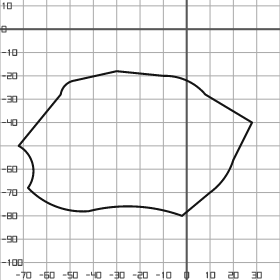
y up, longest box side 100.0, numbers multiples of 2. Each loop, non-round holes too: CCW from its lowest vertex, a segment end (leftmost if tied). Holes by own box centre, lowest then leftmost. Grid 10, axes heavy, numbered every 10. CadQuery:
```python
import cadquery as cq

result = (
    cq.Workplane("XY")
    .moveTo(-2.0, -80.0)
    .lineTo(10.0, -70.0)
    .threePointArc((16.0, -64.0), (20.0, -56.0))
    .lineTo(28.0, -40.0)
    .lineTo(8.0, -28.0)
    .threePointArc((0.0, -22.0), (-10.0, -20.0))
    .lineTo(-30.0, -18.0)
    .lineTo(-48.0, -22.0)
    .threePointArc((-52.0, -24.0), (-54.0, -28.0))
    .lineTo(-72.0, -50.0)
    .threePointArc((-66.0, -58.0), (-68.0, -68.0))
    .threePointArc((-56.0, -76.0), (-42.0, -78.0))
    .threePointArc((-22.0, -76.0), (-2.0, -80.0))
    .close()
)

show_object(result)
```